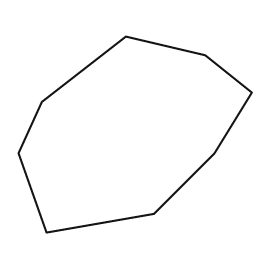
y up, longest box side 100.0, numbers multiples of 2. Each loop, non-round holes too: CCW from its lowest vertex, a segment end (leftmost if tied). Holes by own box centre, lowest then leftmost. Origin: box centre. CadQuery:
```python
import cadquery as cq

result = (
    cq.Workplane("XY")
    .moveTo(-38.0, -42.0)
    .lineTo(8.0, -34.0)
    .lineTo(34.0, -8.0)
    .lineTo(50.0, 18.0)
    .lineTo(30.0, 34.0)
    .lineTo(-4.0, 42.0)
    .lineTo(-40.0, 14.0)
    .lineTo(-50.0, -8.0)
    .close()
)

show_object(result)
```